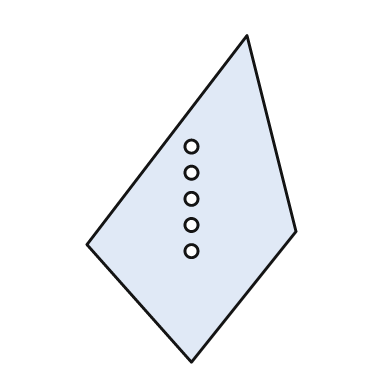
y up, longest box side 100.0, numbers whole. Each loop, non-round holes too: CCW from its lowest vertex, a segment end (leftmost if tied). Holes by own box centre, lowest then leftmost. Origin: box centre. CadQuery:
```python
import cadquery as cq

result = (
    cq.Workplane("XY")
    .moveTo(0.0, -50.0)
    .lineTo(32.0, -10.0)
    .lineTo(17.0, 50.0)
    .lineTo(-32.0, -14.0)
    .close()
    .moveTo(0.0, -16.0)
    .circle(2.0)
    .moveTo(0.0, -8.0)
    .circle(2.0)
    .moveTo(0.0, 0.0)
    .circle(2.0)
    .moveTo(0.0, 8.0)
    .circle(2.0)
    .moveTo(0.0, 16.0)
    .circle(2.0)
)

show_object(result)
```